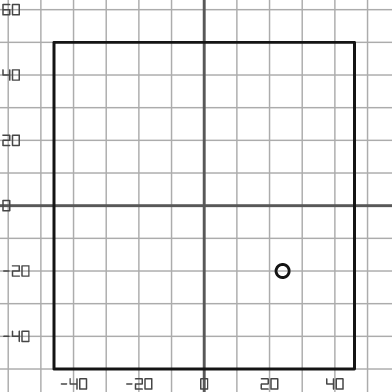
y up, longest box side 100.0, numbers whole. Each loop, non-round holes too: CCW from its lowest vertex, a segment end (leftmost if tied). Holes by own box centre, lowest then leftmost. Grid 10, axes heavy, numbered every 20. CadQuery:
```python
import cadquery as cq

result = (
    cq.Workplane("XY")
    .moveTo(-46.0, -50.0)
    .lineTo(46.0, -50.0)
    .lineTo(46.0, 50.0)
    .lineTo(-46.0, 50.0)
    .close()
    .moveTo(24.0, -20.0)
    .circle(2.0)
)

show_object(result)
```